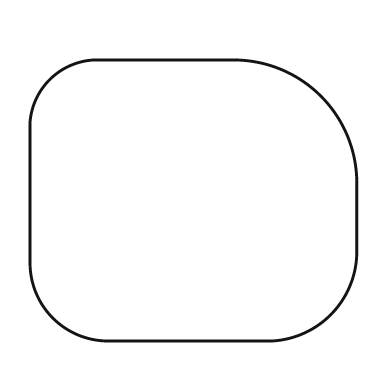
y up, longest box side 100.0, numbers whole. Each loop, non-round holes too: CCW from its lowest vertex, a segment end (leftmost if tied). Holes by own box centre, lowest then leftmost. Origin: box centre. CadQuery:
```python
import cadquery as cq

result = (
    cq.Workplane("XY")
    .moveTo(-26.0, -43.0)
    .lineTo(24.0, -43.0)
    .threePointArc((42.0, -35.0), (50.0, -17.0))
    .lineTo(50.0, 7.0)
    .threePointArc((39.0, 32.0), (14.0, 43.0))
    .lineTo(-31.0, 43.0)
    .threePointArc((-44.0, 37.0), (-50.0, 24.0))
    .lineTo(-50.0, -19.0)
    .threePointArc((-43.0, -36.0), (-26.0, -43.0))
    .close()
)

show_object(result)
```